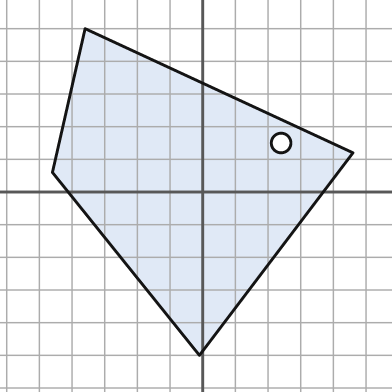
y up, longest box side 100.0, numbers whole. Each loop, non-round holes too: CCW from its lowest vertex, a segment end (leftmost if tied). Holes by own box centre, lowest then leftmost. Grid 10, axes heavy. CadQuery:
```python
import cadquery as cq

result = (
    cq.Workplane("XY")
    .moveTo(-1.0, -50.0)
    .lineTo(46.0, 12.0)
    .lineTo(-36.0, 50.0)
    .lineTo(-46.0, 6.0)
    .close()
    .moveTo(24.0, 15.0)
    .circle(3.0)
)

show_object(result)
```